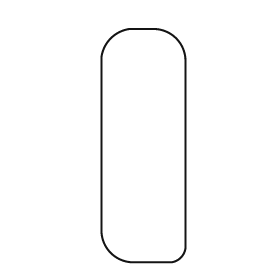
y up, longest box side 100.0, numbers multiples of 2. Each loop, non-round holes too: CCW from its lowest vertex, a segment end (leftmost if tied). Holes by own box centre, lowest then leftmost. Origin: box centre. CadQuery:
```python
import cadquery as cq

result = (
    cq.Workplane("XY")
    .moveTo(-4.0, -50.0)
    .lineTo(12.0, -50.0)
    .threePointArc((16.0, -48.0), (18.0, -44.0))
    .lineTo(18.0, 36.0)
    .threePointArc((14.0, 46.0), (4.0, 50.0))
    .lineTo(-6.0, 50.0)
    .threePointArc((-14.0, 46.0), (-18.0, 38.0))
    .lineTo(-18.0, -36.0)
    .threePointArc((-14.0, -46.0), (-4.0, -50.0))
    .close()
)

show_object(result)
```